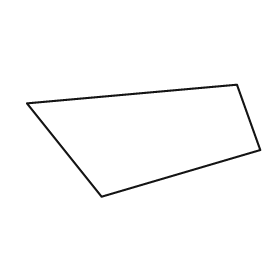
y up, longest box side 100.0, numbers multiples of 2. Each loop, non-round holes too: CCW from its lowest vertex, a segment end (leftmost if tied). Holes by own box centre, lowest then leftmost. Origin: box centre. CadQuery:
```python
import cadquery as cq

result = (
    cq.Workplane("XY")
    .moveTo(-18.0, -24.0)
    .lineTo(50.0, -4.0)
    .lineTo(40.0, 24.0)
    .lineTo(-50.0, 16.0)
    .close()
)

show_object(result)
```